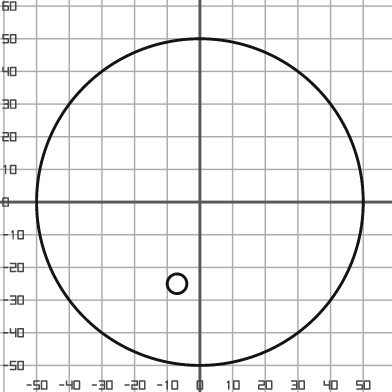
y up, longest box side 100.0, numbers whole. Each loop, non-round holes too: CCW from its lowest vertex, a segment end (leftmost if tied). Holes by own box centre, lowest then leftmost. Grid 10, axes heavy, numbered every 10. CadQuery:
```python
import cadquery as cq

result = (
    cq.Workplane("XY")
    .moveTo(0.0, 0.0)
    .circle(50.0)
    .moveTo(-7.0, -25.0)
    .circle(3.0)
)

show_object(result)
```